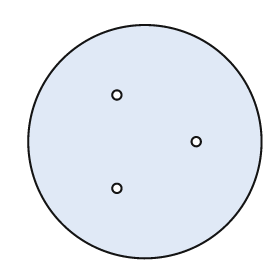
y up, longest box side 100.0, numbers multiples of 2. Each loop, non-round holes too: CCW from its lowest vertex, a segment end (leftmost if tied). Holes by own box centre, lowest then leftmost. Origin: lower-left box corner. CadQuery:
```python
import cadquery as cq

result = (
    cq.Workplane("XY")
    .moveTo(50.0, 50.0)
    .circle(50.0)
    .moveTo(38.0, 30.0)
    .circle(2.0)
    .moveTo(72.0, 50.0)
    .circle(2.0)
    .moveTo(38.0, 70.0)
    .circle(2.0)
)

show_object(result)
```